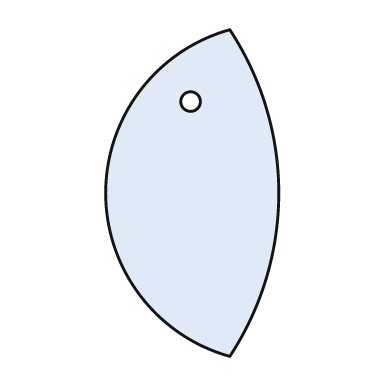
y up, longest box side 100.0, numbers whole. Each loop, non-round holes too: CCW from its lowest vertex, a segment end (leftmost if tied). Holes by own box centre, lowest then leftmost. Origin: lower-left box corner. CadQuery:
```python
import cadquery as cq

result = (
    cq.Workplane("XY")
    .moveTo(38.0, 0.0)
    .threePointArc((53.0, 50.0), (38.0, 100.0))
    .threePointArc((0.0, 50.0), (38.0, 0.0))
    .close()
    .moveTo(26.0, 78.0)
    .circle(3.0)
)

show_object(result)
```